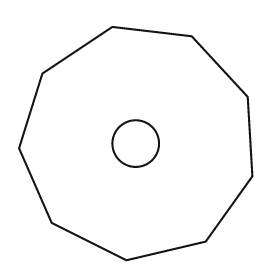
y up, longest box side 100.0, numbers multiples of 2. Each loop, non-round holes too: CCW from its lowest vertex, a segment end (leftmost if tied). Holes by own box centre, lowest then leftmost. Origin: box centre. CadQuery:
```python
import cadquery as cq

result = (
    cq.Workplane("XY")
    .moveTo(-4.0, -50.0)
    .lineTo(30.0, -42.0)
    .lineTo(50.0, -14.0)
    .lineTo(48.0, 20.0)
    .lineTo(24.0, 46.0)
    .lineTo(-10.0, 50.0)
    .lineTo(-40.0, 30.0)
    .lineTo(-50.0, -2.0)
    .lineTo(-36.0, -34.0)
    .close()
    .moveTo(0.0, 0.0)
    .circle(10.0)
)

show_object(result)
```